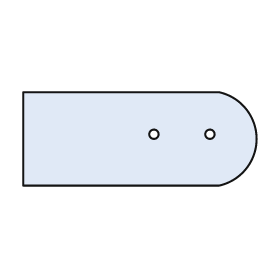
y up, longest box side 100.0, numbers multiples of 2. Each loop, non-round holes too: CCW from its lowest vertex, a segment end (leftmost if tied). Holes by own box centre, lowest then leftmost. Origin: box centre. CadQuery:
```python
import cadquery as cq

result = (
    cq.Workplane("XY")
    .moveTo(-50.0, -20.0)
    .lineTo(34.0, -20.0)
    .threePointArc((50.0, 0.0), (34.0, 20.0))
    .lineTo(-50.0, 20.0)
    .close()
    .moveTo(6.0, 2.0)
    .circle(2.0)
    .moveTo(30.0, 2.0)
    .circle(2.0)
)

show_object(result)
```